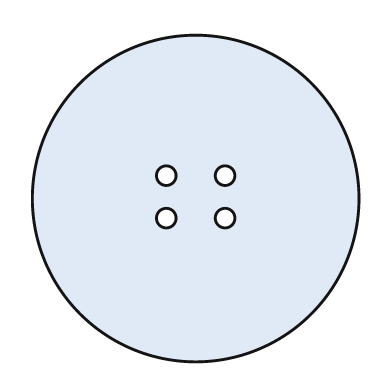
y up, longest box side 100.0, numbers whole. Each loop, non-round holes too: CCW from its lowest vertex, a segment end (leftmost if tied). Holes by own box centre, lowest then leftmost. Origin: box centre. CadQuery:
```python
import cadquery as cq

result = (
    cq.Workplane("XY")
    .moveTo(0.0, 0.0)
    .circle(50.0)
    .moveTo(-9.0, -6.0)
    .circle(3.0)
    .moveTo(9.0, -6.0)
    .circle(3.0)
    .moveTo(-9.0, 7.0)
    .circle(3.0)
    .moveTo(9.0, 7.0)
    .circle(3.0)
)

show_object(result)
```